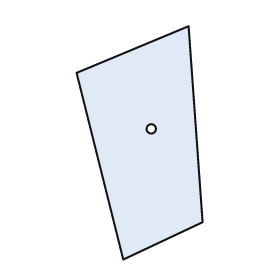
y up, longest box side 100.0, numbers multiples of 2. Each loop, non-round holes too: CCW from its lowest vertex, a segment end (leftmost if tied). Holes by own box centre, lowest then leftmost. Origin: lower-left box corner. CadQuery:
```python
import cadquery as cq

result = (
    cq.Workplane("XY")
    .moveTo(20.0, 0.0)
    .lineTo(54.0, 16.0)
    .lineTo(48.0, 100.0)
    .lineTo(0.0, 80.0)
    .close()
    .moveTo(32.0, 56.0)
    .circle(2.0)
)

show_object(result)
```